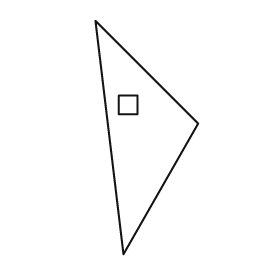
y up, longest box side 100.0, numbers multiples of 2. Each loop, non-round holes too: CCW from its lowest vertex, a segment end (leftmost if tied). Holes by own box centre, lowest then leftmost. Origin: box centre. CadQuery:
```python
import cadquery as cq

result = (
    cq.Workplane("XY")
    .moveTo(-10.0, -50.0)
    .lineTo(22.0, 6.0)
    .lineTo(-22.0, 50.0)
    .close()
    .moveTo(-12.0, 10.0)
    .lineTo(-4.0, 10.0)
    .lineTo(-4.0, 18.0)
    .lineTo(-12.0, 18.0)
    .close()
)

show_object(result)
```